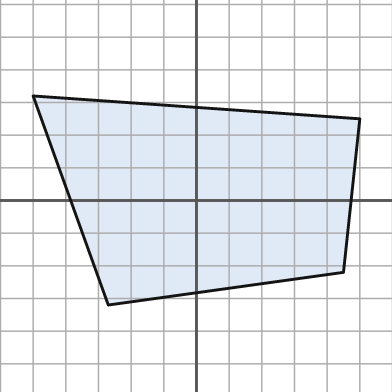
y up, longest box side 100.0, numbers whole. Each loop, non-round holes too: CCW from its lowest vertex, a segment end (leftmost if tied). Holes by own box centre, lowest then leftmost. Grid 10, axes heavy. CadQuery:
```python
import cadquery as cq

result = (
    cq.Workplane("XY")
    .moveTo(-27.0, -32.0)
    .lineTo(45.0, -22.0)
    .lineTo(50.0, 25.0)
    .lineTo(-50.0, 32.0)
    .close()
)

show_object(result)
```